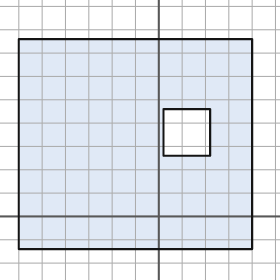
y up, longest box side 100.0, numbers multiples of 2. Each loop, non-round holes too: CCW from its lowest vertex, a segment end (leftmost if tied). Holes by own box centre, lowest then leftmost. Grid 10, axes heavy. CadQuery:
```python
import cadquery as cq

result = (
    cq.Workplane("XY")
    .moveTo(-60.0, -14.0)
    .lineTo(40.0, -14.0)
    .lineTo(40.0, 76.0)
    .lineTo(-60.0, 76.0)
    .close()
    .moveTo(2.0, 26.0)
    .lineTo(22.0, 26.0)
    .lineTo(22.0, 46.0)
    .lineTo(2.0, 46.0)
    .close()
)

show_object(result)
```